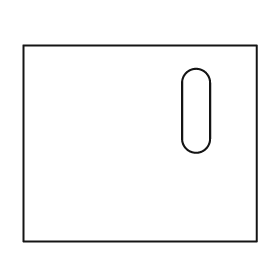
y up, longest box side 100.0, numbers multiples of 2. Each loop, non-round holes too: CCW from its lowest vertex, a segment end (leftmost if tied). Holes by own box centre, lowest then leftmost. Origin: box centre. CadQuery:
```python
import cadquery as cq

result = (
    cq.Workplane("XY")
    .moveTo(-50.0, -42.0)
    .lineTo(50.0, -42.0)
    .lineTo(50.0, 42.0)
    .lineTo(-50.0, 42.0)
    .close()
    .moveTo(18.0, 2.0)
    .threePointArc((24.0, -4.0), (30.0, 2.0))
    .lineTo(30.0, 26.0)
    .threePointArc((24.0, 32.0), (18.0, 26.0))
    .close()
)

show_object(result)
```